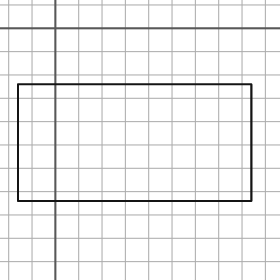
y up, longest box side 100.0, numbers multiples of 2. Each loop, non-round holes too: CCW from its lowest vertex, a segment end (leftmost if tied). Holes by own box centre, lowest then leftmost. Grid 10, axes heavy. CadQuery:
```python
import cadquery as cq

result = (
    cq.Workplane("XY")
    .moveTo(-16.0, -74.0)
    .lineTo(84.0, -74.0)
    .lineTo(84.0, -24.0)
    .lineTo(-16.0, -24.0)
    .close()
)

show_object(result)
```